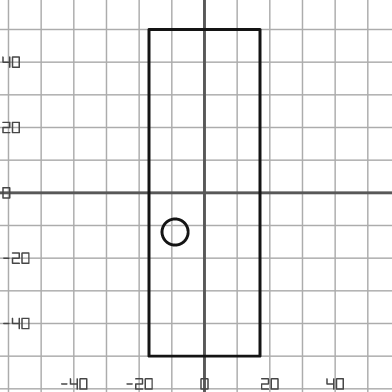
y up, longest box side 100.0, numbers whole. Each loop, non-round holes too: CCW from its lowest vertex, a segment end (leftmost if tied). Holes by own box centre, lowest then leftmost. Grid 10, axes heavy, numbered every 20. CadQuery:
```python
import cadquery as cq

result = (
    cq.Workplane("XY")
    .moveTo(-17.0, -50.0)
    .lineTo(17.0, -50.0)
    .lineTo(17.0, 50.0)
    .lineTo(-17.0, 50.0)
    .close()
    .moveTo(-9.0, -12.0)
    .circle(4.0)
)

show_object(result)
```